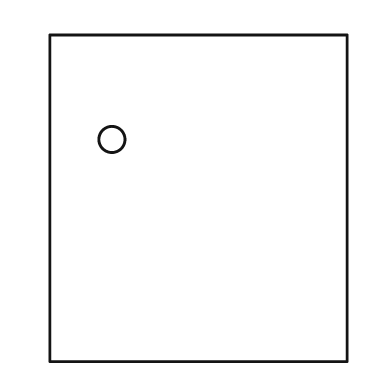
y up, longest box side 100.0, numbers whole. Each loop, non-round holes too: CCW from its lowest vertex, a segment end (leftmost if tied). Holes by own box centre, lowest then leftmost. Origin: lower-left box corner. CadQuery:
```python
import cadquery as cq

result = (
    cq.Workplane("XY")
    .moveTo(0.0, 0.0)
    .lineTo(91.0, 0.0)
    .lineTo(91.0, 100.0)
    .lineTo(0.0, 100.0)
    .close()
    .moveTo(19.0, 68.0)
    .circle(4.0)
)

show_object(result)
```